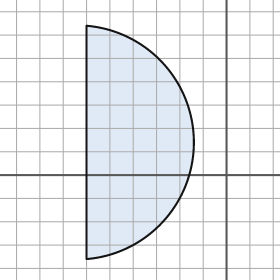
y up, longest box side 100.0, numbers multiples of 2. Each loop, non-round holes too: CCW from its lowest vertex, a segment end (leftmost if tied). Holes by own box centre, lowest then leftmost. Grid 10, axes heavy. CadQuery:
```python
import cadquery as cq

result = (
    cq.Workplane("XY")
    .moveTo(-60.0, -36.0)
    .threePointArc((-14.0, 14.0), (-60.0, 64.0))
    .close()
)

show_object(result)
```